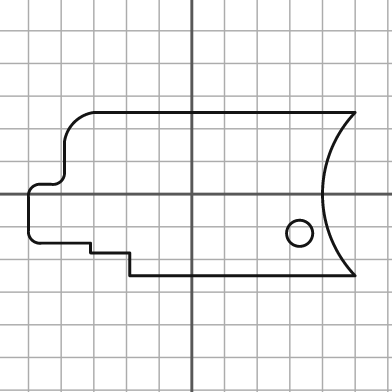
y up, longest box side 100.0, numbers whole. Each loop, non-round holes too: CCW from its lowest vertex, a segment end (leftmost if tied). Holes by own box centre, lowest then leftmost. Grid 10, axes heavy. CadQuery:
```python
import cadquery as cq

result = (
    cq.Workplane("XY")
    .moveTo(-19.0, -25.0)
    .lineTo(50.0, -25.0)
    .threePointArc((40.0, 0.0), (50.0, 25.0))
    .lineTo(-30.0, 25.0)
    .threePointArc((-36.0, 22.0), (-39.0, 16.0))
    .lineTo(-39.0, 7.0)
    .threePointArc((-40.0, 4.0), (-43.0, 3.0))
    .lineTo(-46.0, 3.0)
    .threePointArc((-49.0, 2.0), (-50.0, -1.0))
    .lineTo(-50.0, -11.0)
    .threePointArc((-49.0, -14.0), (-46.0, -15.0))
    .lineTo(-31.0, -15.0)
    .lineTo(-31.0, -18.0)
    .lineTo(-19.0, -18.0)
    .close()
    .moveTo(33.0, -12.0)
    .circle(4.0)
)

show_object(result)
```